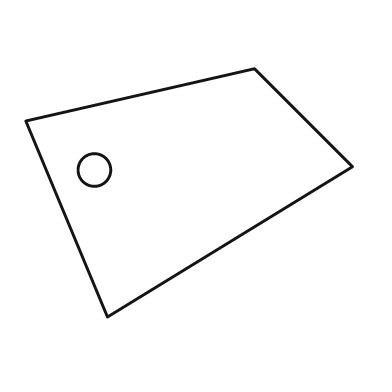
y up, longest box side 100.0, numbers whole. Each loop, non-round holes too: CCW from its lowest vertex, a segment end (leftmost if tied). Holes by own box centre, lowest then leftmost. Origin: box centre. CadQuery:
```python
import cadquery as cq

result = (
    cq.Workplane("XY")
    .moveTo(-25.0, -38.0)
    .lineTo(50.0, 8.0)
    .lineTo(20.0, 38.0)
    .lineTo(-50.0, 22.0)
    .close()
    .moveTo(-29.0, 7.0)
    .circle(5.0)
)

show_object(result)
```